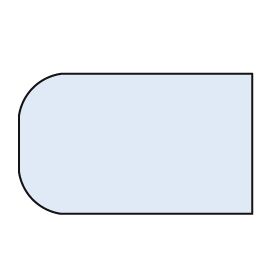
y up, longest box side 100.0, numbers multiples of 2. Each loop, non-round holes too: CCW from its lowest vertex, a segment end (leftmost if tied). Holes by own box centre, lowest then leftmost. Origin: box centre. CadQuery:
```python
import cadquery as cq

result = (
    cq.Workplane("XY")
    .moveTo(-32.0, -30.0)
    .lineTo(50.0, -30.0)
    .lineTo(50.0, 30.0)
    .lineTo(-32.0, 30.0)
    .threePointArc((-44.0, 24.0), (-50.0, 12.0))
    .lineTo(-50.0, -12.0)
    .threePointArc((-44.0, -24.0), (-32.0, -30.0))
    .close()
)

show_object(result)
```